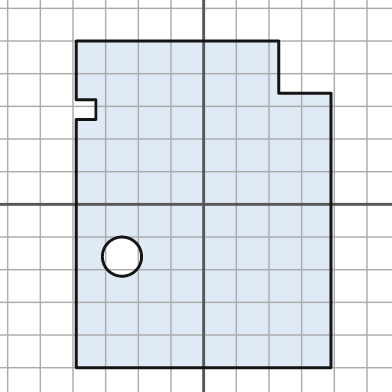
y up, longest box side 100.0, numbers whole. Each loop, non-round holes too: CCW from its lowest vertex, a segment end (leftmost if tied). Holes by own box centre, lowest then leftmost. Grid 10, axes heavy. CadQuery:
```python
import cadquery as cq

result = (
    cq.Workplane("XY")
    .moveTo(-39.0, -50.0)
    .lineTo(39.0, -50.0)
    .lineTo(39.0, 34.0)
    .lineTo(23.0, 34.0)
    .lineTo(23.0, 50.0)
    .lineTo(-39.0, 50.0)
    .lineTo(-39.0, 32.0)
    .lineTo(-33.0, 32.0)
    .lineTo(-33.0, 26.0)
    .lineTo(-39.0, 26.0)
    .close()
    .moveTo(-25.0, -16.0)
    .circle(6.0)
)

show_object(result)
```